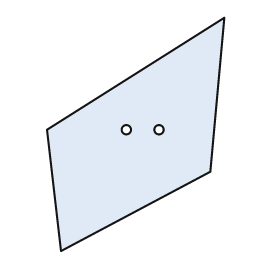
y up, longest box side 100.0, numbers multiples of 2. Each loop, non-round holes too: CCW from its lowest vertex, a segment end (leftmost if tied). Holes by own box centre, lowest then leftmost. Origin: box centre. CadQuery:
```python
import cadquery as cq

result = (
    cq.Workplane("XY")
    .moveTo(-32.0, -50.0)
    .lineTo(32.0, -16.0)
    .lineTo(38.0, 50.0)
    .lineTo(-38.0, 2.0)
    .close()
    .moveTo(-4.0, 2.0)
    .circle(2.0)
    .moveTo(10.0, 2.0)
    .circle(2.0)
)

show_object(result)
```